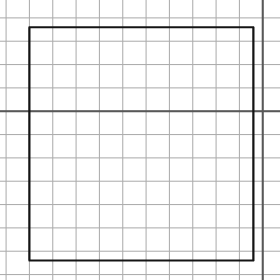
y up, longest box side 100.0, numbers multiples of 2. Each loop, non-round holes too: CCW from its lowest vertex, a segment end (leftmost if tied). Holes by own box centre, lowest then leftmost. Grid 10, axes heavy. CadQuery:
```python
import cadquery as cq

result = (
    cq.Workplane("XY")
    .moveTo(-100.0, -64.0)
    .lineTo(-4.0, -64.0)
    .lineTo(-4.0, 36.0)
    .lineTo(-100.0, 36.0)
    .close()
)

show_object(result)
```